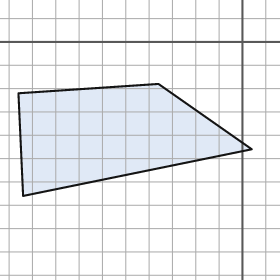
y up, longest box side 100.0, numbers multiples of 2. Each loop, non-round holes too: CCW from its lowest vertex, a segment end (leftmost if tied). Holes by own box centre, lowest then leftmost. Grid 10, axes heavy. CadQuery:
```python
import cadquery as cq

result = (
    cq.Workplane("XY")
    .moveTo(-94.0, -66.0)
    .lineTo(4.0, -46.0)
    .lineTo(-36.0, -18.0)
    .lineTo(-96.0, -22.0)
    .close()
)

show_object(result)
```